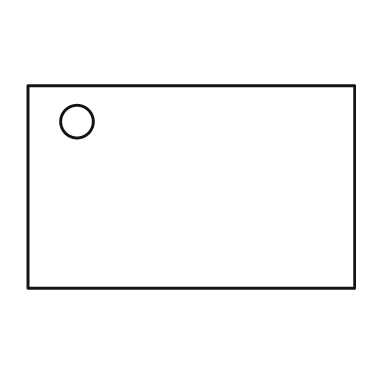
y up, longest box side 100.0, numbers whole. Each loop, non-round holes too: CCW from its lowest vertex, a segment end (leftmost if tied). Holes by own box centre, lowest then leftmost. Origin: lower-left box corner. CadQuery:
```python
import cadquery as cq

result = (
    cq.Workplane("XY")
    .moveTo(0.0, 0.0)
    .lineTo(100.0, 0.0)
    .lineTo(100.0, 62.0)
    .lineTo(0.0, 62.0)
    .close()
    .moveTo(15.0, 51.0)
    .circle(5.0)
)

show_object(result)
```